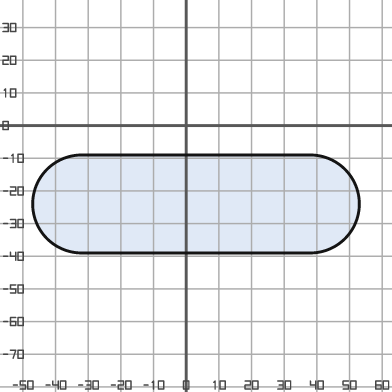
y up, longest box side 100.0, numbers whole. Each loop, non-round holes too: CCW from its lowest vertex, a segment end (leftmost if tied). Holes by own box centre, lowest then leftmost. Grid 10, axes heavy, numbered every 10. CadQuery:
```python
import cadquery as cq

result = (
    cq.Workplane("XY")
    .moveTo(-32.0, -39.0)
    .lineTo(38.0, -39.0)
    .threePointArc((53.0, -24.0), (38.0, -9.0))
    .lineTo(-32.0, -9.0)
    .threePointArc((-47.0, -24.0), (-32.0, -39.0))
    .close()
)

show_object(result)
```